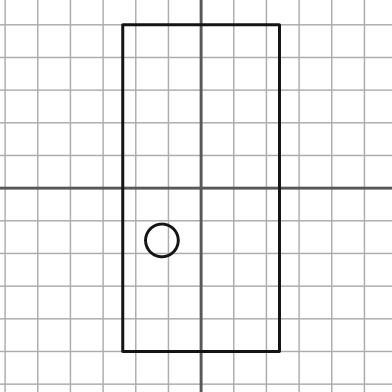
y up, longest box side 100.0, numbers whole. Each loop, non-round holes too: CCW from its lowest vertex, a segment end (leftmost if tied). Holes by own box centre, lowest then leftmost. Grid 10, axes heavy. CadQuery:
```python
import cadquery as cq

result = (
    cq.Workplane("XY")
    .moveTo(-24.0, -50.0)
    .lineTo(24.0, -50.0)
    .lineTo(24.0, 50.0)
    .lineTo(-24.0, 50.0)
    .close()
    .moveTo(-12.0, -16.0)
    .circle(5.0)
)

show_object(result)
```